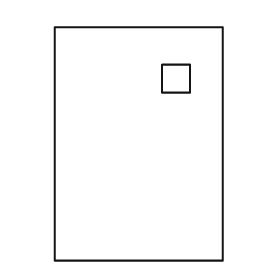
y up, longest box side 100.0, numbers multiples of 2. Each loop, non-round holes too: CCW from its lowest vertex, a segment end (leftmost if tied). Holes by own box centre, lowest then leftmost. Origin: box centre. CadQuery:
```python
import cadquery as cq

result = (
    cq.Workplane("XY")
    .moveTo(-36.0, -50.0)
    .lineTo(36.0, -50.0)
    .lineTo(36.0, 50.0)
    .lineTo(-36.0, 50.0)
    .close()
    .moveTo(10.0, 22.0)
    .lineTo(22.0, 22.0)
    .lineTo(22.0, 34.0)
    .lineTo(10.0, 34.0)
    .close()
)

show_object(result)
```